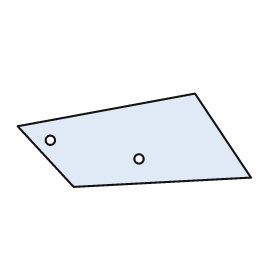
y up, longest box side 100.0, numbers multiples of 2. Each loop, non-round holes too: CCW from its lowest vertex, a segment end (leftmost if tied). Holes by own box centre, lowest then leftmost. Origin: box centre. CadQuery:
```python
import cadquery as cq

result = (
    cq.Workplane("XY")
    .moveTo(-26.0, -20.0)
    .lineTo(50.0, -16.0)
    .lineTo(26.0, 20.0)
    .lineTo(-50.0, 6.0)
    .close()
    .moveTo(2.0, -8.0)
    .circle(2.0)
    .moveTo(-36.0, 0.0)
    .circle(2.0)
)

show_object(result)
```